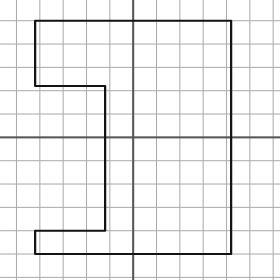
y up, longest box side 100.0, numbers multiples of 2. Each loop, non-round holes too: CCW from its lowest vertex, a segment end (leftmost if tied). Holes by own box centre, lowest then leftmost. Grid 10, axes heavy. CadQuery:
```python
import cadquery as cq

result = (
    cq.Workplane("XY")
    .moveTo(-42.0, -50.0)
    .lineTo(42.0, -50.0)
    .lineTo(42.0, 50.0)
    .lineTo(-42.0, 50.0)
    .lineTo(-42.0, 22.0)
    .lineTo(-12.0, 22.0)
    .lineTo(-12.0, -40.0)
    .lineTo(-42.0, -40.0)
    .close()
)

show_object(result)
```